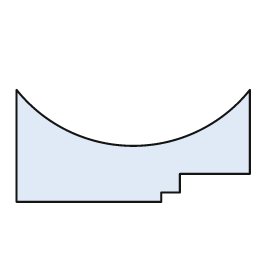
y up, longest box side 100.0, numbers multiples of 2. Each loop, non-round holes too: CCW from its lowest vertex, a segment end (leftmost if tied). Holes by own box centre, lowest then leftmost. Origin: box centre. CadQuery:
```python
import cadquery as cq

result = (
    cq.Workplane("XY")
    .moveTo(-50.0, -24.0)
    .lineTo(12.0, -24.0)
    .lineTo(12.0, -20.0)
    .lineTo(20.0, -20.0)
    .lineTo(20.0, -12.0)
    .lineTo(50.0, -12.0)
    .lineTo(50.0, 24.0)
    .threePointArc((0.0, 0.0), (-50.0, 24.0))
    .close()
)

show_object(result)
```